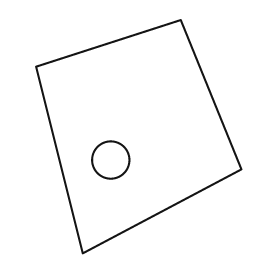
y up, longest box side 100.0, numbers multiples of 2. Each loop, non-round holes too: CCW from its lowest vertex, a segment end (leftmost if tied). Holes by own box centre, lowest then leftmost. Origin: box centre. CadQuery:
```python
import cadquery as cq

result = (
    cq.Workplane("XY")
    .moveTo(-24.0, -50.0)
    .lineTo(44.0, -14.0)
    .lineTo(18.0, 50.0)
    .lineTo(-44.0, 30.0)
    .close()
    .moveTo(-12.0, -10.0)
    .circle(8.0)
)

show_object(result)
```